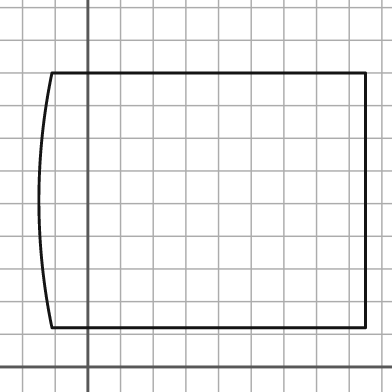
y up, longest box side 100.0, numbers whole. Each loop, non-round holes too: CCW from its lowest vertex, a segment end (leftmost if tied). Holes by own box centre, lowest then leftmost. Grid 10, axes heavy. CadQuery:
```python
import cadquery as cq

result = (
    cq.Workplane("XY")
    .moveTo(-11.0, 12.0)
    .lineTo(85.0, 12.0)
    .lineTo(85.0, 90.0)
    .lineTo(-11.0, 90.0)
    .threePointArc((-15.0, 51.0), (-11.0, 12.0))
    .close()
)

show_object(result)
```